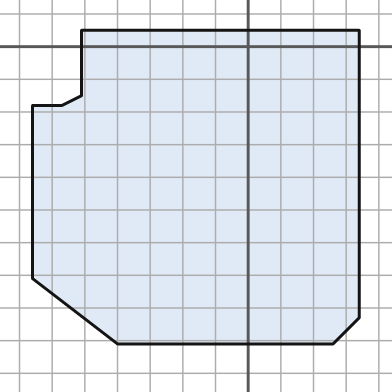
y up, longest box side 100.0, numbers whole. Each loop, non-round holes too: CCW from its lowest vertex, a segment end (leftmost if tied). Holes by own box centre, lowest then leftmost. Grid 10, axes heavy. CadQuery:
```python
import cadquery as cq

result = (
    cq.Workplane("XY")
    .moveTo(-40.0, -91.0)
    .lineTo(26.0, -91.0)
    .lineTo(34.0, -83.0)
    .lineTo(34.0, 5.0)
    .lineTo(-51.0, 5.0)
    .lineTo(-51.0, -15.0)
    .lineTo(-57.0, -18.0)
    .lineTo(-66.0, -18.0)
    .lineTo(-66.0, -71.0)
    .close()
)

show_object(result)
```